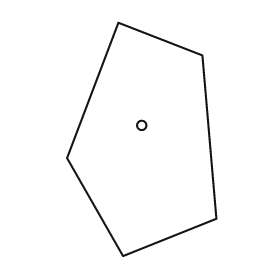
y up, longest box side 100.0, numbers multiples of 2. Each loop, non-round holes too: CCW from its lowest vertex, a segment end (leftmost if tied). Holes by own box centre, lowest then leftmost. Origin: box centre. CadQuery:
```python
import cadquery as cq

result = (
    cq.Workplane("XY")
    .moveTo(-8.0, -50.0)
    .lineTo(32.0, -34.0)
    .lineTo(26.0, 36.0)
    .lineTo(-10.0, 50.0)
    .lineTo(-32.0, -8.0)
    .close()
    .moveTo(0.0, 6.0)
    .circle(2.0)
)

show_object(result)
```